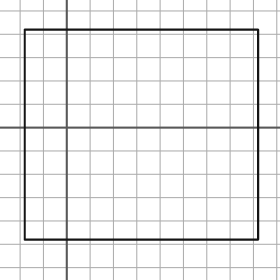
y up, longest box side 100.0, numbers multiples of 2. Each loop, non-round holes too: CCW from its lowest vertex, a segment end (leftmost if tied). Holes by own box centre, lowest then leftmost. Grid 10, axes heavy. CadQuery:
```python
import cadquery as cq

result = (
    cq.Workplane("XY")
    .moveTo(-18.0, -48.0)
    .lineTo(82.0, -48.0)
    .lineTo(82.0, 42.0)
    .lineTo(-18.0, 42.0)
    .close()
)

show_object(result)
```